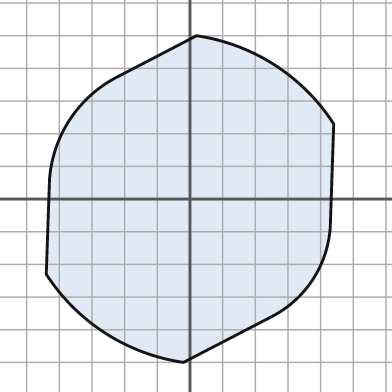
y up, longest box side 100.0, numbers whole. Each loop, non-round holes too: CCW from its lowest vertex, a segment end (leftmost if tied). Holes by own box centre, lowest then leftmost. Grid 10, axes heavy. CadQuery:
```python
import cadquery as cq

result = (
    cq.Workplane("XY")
    .moveTo(-2.0, -50.0)
    .lineTo(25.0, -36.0)
    .threePointArc((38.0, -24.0), (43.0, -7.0))
    .lineTo(44.0, 23.0)
    .threePointArc((26.0, 41.0), (2.0, 50.0))
    .lineTo(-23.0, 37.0)
    .threePointArc((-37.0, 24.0), (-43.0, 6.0))
    .lineTo(-44.0, -23.0)
    .threePointArc((-26.0, -41.0), (-2.0, -50.0))
    .close()
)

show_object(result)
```